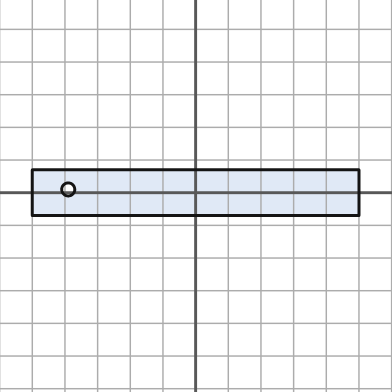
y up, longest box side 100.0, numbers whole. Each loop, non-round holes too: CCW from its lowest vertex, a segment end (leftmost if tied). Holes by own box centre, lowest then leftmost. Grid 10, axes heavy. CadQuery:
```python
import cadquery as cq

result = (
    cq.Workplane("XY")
    .moveTo(-50.0, -7.0)
    .lineTo(50.0, -7.0)
    .lineTo(50.0, 7.0)
    .lineTo(-50.0, 7.0)
    .close()
    .moveTo(-39.0, 1.0)
    .circle(2.0)
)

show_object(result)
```